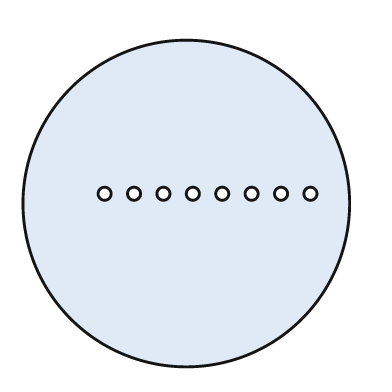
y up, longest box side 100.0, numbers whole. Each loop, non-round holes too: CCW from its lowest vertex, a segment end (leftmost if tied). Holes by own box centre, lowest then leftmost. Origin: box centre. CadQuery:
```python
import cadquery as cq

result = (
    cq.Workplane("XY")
    .moveTo(0.0, 0.0)
    .circle(50.0)
    .moveTo(-25.0, 3.0)
    .circle(2.0)
    .moveTo(-16.0, 3.0)
    .circle(2.0)
    .moveTo(-7.0, 3.0)
    .circle(2.0)
    .moveTo(2.0, 3.0)
    .circle(2.0)
    .moveTo(11.0, 3.0)
    .circle(2.0)
    .moveTo(20.0, 3.0)
    .circle(2.0)
    .moveTo(29.0, 3.0)
    .circle(2.0)
    .moveTo(38.0, 3.0)
    .circle(2.0)
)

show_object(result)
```